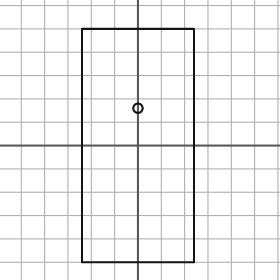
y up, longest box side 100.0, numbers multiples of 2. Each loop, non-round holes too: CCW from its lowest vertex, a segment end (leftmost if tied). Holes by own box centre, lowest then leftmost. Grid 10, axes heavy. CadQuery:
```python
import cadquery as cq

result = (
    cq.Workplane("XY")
    .moveTo(-24.0, -50.0)
    .lineTo(24.0, -50.0)
    .lineTo(24.0, 50.0)
    .lineTo(-24.0, 50.0)
    .close()
    .moveTo(0.0, 16.0)
    .circle(2.0)
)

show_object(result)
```